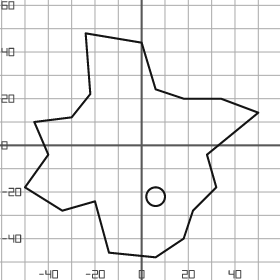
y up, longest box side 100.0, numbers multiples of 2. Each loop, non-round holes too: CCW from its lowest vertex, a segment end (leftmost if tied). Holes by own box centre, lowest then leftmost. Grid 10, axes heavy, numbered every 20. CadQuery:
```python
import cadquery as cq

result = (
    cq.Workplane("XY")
    .moveTo(6.0, -48.0)
    .lineTo(18.0, -40.0)
    .lineTo(22.0, -28.0)
    .lineTo(32.0, -18.0)
    .lineTo(28.0, -4.0)
    .lineTo(50.0, 14.0)
    .lineTo(34.0, 20.0)
    .lineTo(18.0, 20.0)
    .lineTo(6.0, 24.0)
    .lineTo(0.0, 44.0)
    .lineTo(-24.0, 48.0)
    .lineTo(-22.0, 22.0)
    .lineTo(-30.0, 12.0)
    .lineTo(-46.0, 10.0)
    .lineTo(-40.0, -4.0)
    .lineTo(-50.0, -18.0)
    .lineTo(-34.0, -28.0)
    .lineTo(-20.0, -24.0)
    .lineTo(-14.0, -46.0)
    .close()
    .moveTo(6.0, -22.0)
    .circle(4.0)
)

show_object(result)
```